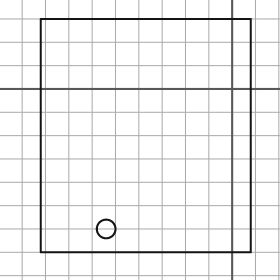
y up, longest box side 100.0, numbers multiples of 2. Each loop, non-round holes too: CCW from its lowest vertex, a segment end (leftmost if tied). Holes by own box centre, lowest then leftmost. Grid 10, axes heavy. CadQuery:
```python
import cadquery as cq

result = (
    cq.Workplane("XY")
    .moveTo(-82.0, -70.0)
    .lineTo(8.0, -70.0)
    .lineTo(8.0, 30.0)
    .lineTo(-82.0, 30.0)
    .close()
    .moveTo(-54.0, -60.0)
    .circle(4.0)
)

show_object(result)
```